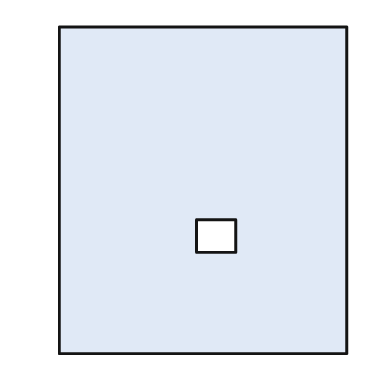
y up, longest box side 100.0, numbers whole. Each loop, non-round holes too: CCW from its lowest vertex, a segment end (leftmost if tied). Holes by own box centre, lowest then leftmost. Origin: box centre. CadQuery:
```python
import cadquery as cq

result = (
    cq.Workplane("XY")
    .moveTo(-44.0, -50.0)
    .lineTo(44.0, -50.0)
    .lineTo(44.0, 50.0)
    .lineTo(-44.0, 50.0)
    .close()
    .moveTo(-2.0, -19.0)
    .lineTo(10.0, -19.0)
    .lineTo(10.0, -9.0)
    .lineTo(-2.0, -9.0)
    .close()
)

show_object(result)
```